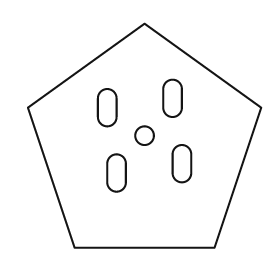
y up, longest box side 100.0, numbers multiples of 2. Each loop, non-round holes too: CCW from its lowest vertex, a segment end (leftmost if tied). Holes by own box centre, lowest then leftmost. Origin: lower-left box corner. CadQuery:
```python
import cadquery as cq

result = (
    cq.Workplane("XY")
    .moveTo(20.0, 0.0)
    .lineTo(80.0, 0.0)
    .lineTo(100.0, 60.0)
    .lineTo(50.0, 96.0)
    .lineTo(0.0, 60.0)
    .close()
    .moveTo(34.0, 28.0)
    .threePointArc((38.0, 24.0), (42.0, 28.0))
    .lineTo(42.0, 36.0)
    .threePointArc((38.0, 40.0), (34.0, 36.0))
    .close()
    .moveTo(62.0, 32.0)
    .threePointArc((66.0, 28.0), (70.0, 32.0))
    .lineTo(70.0, 40.0)
    .threePointArc((66.0, 44.0), (62.0, 40.0))
    .close()
    .moveTo(50.0, 48.0)
    .circle(4.0)
    .moveTo(30.0, 56.0)
    .threePointArc((34.0, 52.0), (38.0, 56.0))
    .lineTo(38.0, 64.0)
    .threePointArc((34.0, 68.0), (30.0, 64.0))
    .close()
    .moveTo(58.0, 60.0)
    .threePointArc((62.0, 56.0), (66.0, 60.0))
    .lineTo(66.0, 68.0)
    .threePointArc((62.0, 72.0), (58.0, 68.0))
    .close()
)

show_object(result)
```